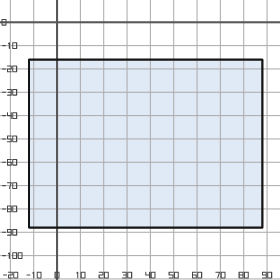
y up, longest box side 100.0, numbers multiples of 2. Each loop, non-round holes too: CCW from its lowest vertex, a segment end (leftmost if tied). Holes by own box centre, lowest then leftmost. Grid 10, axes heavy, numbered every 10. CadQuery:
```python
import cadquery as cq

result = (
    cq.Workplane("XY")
    .moveTo(-12.0, -88.0)
    .lineTo(88.0, -88.0)
    .lineTo(88.0, -16.0)
    .lineTo(-12.0, -16.0)
    .close()
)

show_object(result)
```